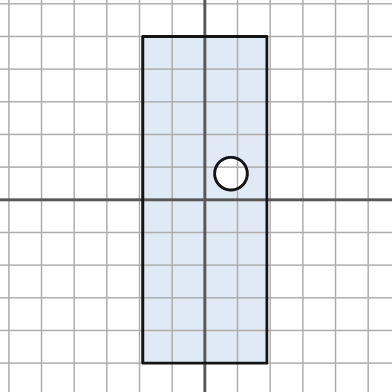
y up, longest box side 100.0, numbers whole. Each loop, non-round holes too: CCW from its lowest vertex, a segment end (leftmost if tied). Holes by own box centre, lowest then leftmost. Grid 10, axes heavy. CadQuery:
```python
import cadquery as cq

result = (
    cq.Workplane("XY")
    .moveTo(-19.0, -50.0)
    .lineTo(19.0, -50.0)
    .lineTo(19.0, 50.0)
    .lineTo(-19.0, 50.0)
    .close()
    .moveTo(8.0, 8.0)
    .circle(5.0)
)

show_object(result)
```